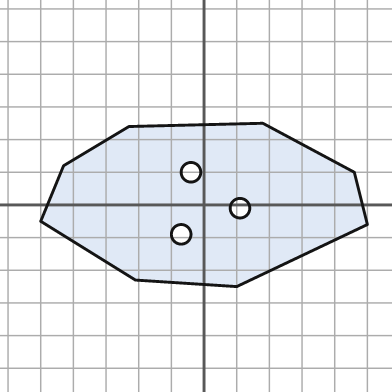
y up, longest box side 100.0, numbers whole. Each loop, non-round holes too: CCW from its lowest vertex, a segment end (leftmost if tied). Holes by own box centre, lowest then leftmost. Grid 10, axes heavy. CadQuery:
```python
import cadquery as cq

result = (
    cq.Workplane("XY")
    .moveTo(10.0, -25.0)
    .lineTo(50.0, -6.0)
    .lineTo(46.0, 10.0)
    .lineTo(18.0, 25.0)
    .lineTo(-23.0, 24.0)
    .lineTo(-43.0, 12.0)
    .lineTo(-50.0, -5.0)
    .lineTo(-21.0, -23.0)
    .close()
    .moveTo(-7.0, -9.0)
    .circle(3.0)
    .moveTo(11.0, -1.0)
    .circle(3.0)
    .moveTo(-4.0, 10.0)
    .circle(3.0)
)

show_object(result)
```